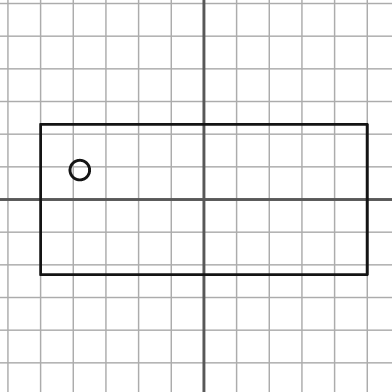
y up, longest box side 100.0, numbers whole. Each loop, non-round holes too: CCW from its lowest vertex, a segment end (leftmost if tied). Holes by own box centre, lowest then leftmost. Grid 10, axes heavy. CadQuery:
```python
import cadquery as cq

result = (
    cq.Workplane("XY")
    .moveTo(-50.0, -23.0)
    .lineTo(50.0, -23.0)
    .lineTo(50.0, 23.0)
    .lineTo(-50.0, 23.0)
    .close()
    .moveTo(-38.0, 9.0)
    .circle(3.0)
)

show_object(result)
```